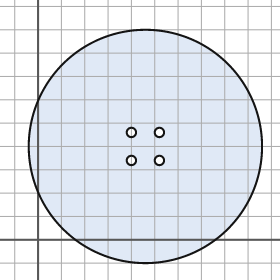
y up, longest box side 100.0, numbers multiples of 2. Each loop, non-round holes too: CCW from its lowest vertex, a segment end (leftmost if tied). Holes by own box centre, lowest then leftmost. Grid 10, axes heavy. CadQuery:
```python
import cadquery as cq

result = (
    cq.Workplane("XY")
    .moveTo(46.0, 40.0)
    .circle(50.0)
    .moveTo(40.0, 34.0)
    .circle(2.0)
    .moveTo(52.0, 34.0)
    .circle(2.0)
    .moveTo(40.0, 46.0)
    .circle(2.0)
    .moveTo(52.0, 46.0)
    .circle(2.0)
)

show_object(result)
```